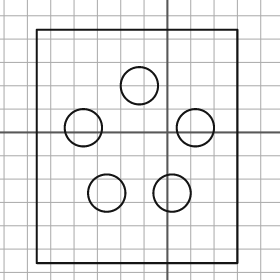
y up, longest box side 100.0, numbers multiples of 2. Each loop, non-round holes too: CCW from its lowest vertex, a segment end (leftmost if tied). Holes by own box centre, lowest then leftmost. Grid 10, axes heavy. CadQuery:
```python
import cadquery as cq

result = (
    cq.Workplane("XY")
    .moveTo(-56.0, -56.0)
    .lineTo(30.0, -56.0)
    .lineTo(30.0, 44.0)
    .lineTo(-56.0, 44.0)
    .close()
    .moveTo(-26.0, -26.0)
    .circle(8.0)
    .moveTo(2.0, -26.0)
    .circle(8.0)
    .moveTo(-36.0, 2.0)
    .circle(8.0)
    .moveTo(12.0, 2.0)
    .circle(8.0)
    .moveTo(-12.0, 20.0)
    .circle(8.0)
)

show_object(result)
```